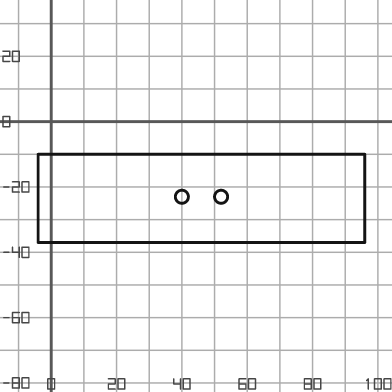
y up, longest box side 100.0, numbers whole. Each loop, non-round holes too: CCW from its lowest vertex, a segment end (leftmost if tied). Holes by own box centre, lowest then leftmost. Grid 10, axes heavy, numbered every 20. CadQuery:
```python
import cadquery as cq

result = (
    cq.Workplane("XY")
    .moveTo(-4.0, -37.0)
    .lineTo(96.0, -37.0)
    .lineTo(96.0, -10.0)
    .lineTo(-4.0, -10.0)
    .close()
    .moveTo(40.0, -23.0)
    .circle(2.0)
    .moveTo(52.0, -23.0)
    .circle(2.0)
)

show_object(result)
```